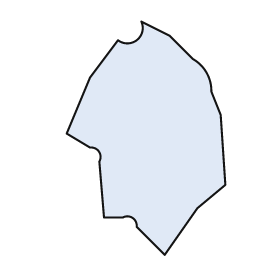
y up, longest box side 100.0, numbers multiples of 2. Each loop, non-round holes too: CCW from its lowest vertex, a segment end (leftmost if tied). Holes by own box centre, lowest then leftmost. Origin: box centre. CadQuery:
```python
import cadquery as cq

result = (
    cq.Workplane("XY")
    .moveTo(8.0, -50.0)
    .lineTo(22.0, -30.0)
    .lineTo(34.0, -20.0)
    .lineTo(32.0, 10.0)
    .lineTo(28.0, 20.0)
    .threePointArc((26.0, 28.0), (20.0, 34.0))
    .lineTo(10.0, 44.0)
    .lineTo(-2.0, 50.0)
    .threePointArc((-4.0, 42.0), (-12.0, 42.0))
    .lineTo(-24.0, 26.0)
    .lineTo(-34.0, 2.0)
    .lineTo(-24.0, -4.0)
    .threePointArc((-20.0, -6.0), (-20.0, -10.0))
    .lineTo(-18.0, -34.0)
    .lineTo(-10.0, -34.0)
    .threePointArc((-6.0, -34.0), (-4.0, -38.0))
    .close()
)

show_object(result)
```